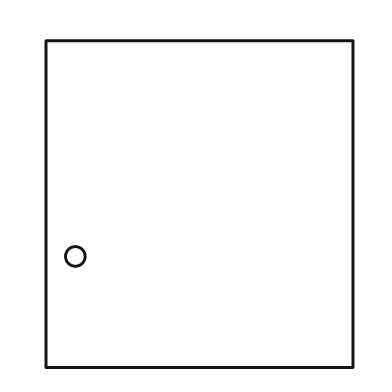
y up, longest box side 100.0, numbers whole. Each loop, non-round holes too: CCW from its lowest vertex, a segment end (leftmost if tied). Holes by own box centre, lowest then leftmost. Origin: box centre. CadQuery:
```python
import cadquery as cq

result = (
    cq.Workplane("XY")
    .moveTo(-47.0, -50.0)
    .lineTo(47.0, -50.0)
    .lineTo(47.0, 50.0)
    .lineTo(-47.0, 50.0)
    .close()
    .moveTo(-38.0, -16.0)
    .circle(3.0)
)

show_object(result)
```